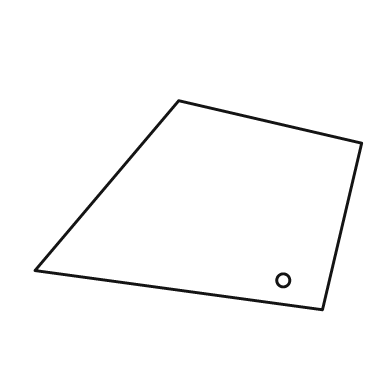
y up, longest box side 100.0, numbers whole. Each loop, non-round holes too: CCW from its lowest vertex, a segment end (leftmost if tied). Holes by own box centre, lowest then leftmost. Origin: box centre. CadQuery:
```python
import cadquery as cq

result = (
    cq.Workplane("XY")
    .moveTo(38.0, -32.0)
    .lineTo(50.0, 19.0)
    .lineTo(-6.0, 32.0)
    .lineTo(-50.0, -20.0)
    .close()
    .moveTo(26.0, -23.0)
    .circle(2.0)
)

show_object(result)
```